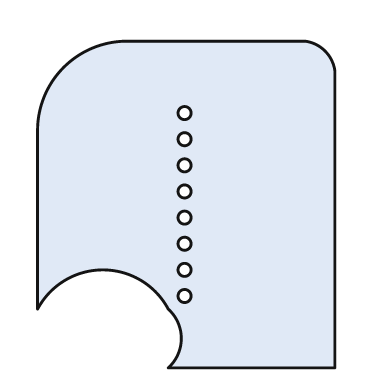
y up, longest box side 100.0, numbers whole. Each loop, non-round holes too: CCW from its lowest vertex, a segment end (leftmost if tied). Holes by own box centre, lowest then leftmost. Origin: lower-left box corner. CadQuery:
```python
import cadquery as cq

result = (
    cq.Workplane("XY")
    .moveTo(40.0, 0.0)
    .lineTo(91.0, 0.0)
    .lineTo(91.0, 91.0)
    .threePointArc((88.0, 97.0), (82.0, 100.0))
    .lineTo(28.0, 100.0)
    .threePointArc((8.0, 92.0), (0.0, 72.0))
    .lineTo(0.0, 18.0)
    .threePointArc((20.0, 30.0), (40.0, 18.0))
    .threePointArc((44.0, 9.0), (40.0, 0.0))
    .close()
    .moveTo(45.0, 22.0)
    .circle(2.0)
    .moveTo(45.0, 30.0)
    .circle(2.0)
    .moveTo(45.0, 38.0)
    .circle(2.0)
    .moveTo(45.0, 46.0)
    .circle(2.0)
    .moveTo(45.0, 54.0)
    .circle(2.0)
    .moveTo(45.0, 62.0)
    .circle(2.0)
    .moveTo(45.0, 70.0)
    .circle(2.0)
    .moveTo(45.0, 78.0)
    .circle(2.0)
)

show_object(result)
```